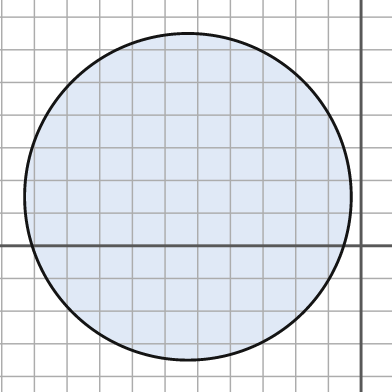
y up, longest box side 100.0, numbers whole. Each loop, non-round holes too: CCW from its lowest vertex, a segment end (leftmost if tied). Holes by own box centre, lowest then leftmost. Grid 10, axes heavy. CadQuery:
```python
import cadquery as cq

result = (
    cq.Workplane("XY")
    .moveTo(-53.0, 15.0)
    .circle(50.0)
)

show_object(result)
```